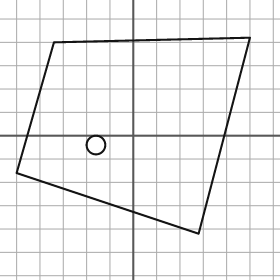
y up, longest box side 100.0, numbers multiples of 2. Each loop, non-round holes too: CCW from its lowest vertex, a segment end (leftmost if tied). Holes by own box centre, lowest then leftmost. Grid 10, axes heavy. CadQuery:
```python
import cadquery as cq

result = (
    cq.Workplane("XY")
    .moveTo(28.0, -42.0)
    .lineTo(50.0, 42.0)
    .lineTo(-34.0, 40.0)
    .lineTo(-50.0, -16.0)
    .close()
    .moveTo(-16.0, -4.0)
    .circle(4.0)
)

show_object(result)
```